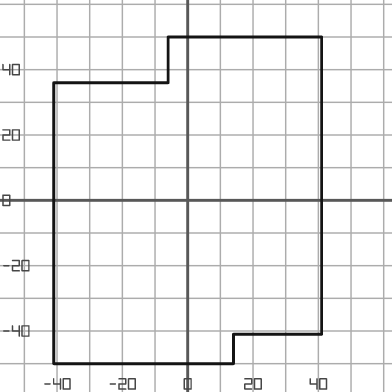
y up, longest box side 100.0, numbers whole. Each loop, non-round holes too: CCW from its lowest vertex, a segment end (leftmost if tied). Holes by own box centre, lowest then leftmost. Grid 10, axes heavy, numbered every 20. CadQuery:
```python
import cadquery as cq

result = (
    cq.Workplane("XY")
    .moveTo(-41.0, -50.0)
    .lineTo(14.0, -50.0)
    .lineTo(14.0, -41.0)
    .lineTo(41.0, -41.0)
    .lineTo(41.0, 50.0)
    .lineTo(-6.0, 50.0)
    .lineTo(-6.0, 36.0)
    .lineTo(-41.0, 36.0)
    .close()
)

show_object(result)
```